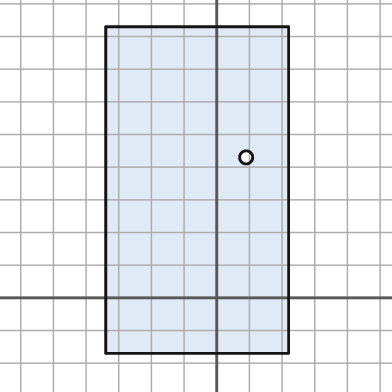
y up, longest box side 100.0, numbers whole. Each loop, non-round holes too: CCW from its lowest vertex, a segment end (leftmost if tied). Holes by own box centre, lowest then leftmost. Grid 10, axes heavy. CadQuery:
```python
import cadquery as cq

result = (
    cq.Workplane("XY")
    .moveTo(-34.0, -17.0)
    .lineTo(22.0, -17.0)
    .lineTo(22.0, 83.0)
    .lineTo(-34.0, 83.0)
    .close()
    .moveTo(9.0, 43.0)
    .circle(2.0)
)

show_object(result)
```